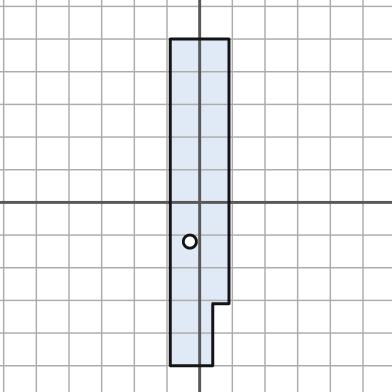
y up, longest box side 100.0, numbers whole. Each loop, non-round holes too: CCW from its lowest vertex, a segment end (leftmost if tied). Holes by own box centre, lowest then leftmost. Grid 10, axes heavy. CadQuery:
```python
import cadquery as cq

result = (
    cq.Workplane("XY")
    .moveTo(-9.0, -50.0)
    .lineTo(4.0, -50.0)
    .lineTo(4.0, -31.0)
    .lineTo(9.0, -31.0)
    .lineTo(9.0, 50.0)
    .lineTo(-9.0, 50.0)
    .close()
    .moveTo(-3.0, -12.0)
    .circle(2.0)
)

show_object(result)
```